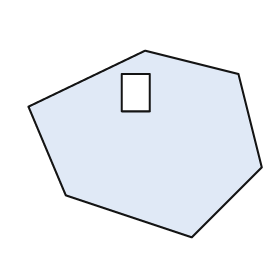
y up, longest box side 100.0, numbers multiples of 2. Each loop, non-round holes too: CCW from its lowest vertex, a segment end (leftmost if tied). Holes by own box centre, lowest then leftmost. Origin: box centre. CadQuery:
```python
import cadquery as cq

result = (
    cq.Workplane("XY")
    .moveTo(20.0, -40.0)
    .lineTo(50.0, -10.0)
    .lineTo(40.0, 30.0)
    .lineTo(0.0, 40.0)
    .lineTo(-50.0, 16.0)
    .lineTo(-34.0, -22.0)
    .close()
    .moveTo(-10.0, 14.0)
    .lineTo(2.0, 14.0)
    .lineTo(2.0, 30.0)
    .lineTo(-10.0, 30.0)
    .close()
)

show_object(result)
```